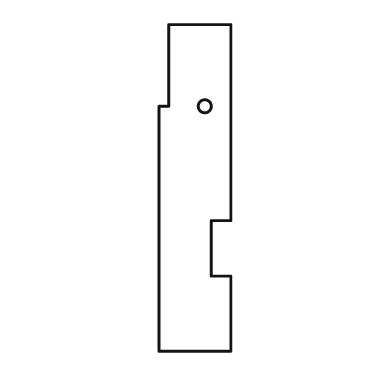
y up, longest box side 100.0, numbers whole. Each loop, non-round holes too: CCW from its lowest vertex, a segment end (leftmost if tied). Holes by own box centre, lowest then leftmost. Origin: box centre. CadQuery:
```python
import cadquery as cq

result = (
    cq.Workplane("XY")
    .moveTo(-11.0, -50.0)
    .lineTo(11.0, -50.0)
    .lineTo(11.0, -27.0)
    .lineTo(5.0, -27.0)
    .lineTo(5.0, -10.0)
    .lineTo(11.0, -10.0)
    .lineTo(11.0, 50.0)
    .lineTo(-8.0, 50.0)
    .lineTo(-8.0, 25.0)
    .lineTo(-11.0, 25.0)
    .close()
    .moveTo(3.0, 25.0)
    .circle(2.0)
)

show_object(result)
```